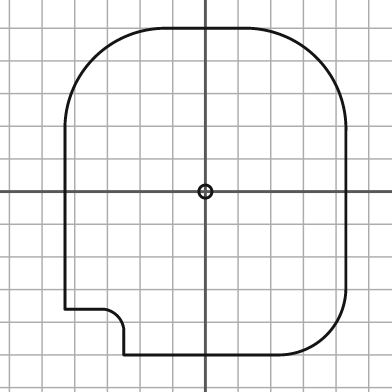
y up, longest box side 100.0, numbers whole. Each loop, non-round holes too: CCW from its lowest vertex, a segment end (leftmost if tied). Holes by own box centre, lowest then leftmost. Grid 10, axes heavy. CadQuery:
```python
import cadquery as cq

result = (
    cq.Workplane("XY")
    .moveTo(-25.0, -50.0)
    .lineTo(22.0, -50.0)
    .threePointArc((37.0, -44.0), (43.0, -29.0))
    .lineTo(43.0, 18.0)
    .threePointArc((34.0, 41.0), (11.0, 50.0))
    .lineTo(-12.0, 50.0)
    .threePointArc((-34.0, 41.0), (-43.0, 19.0))
    .lineTo(-43.0, -36.0)
    .lineTo(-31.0, -36.0)
    .threePointArc((-27.0, -38.0), (-25.0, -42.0))
    .close()
    .moveTo(0.0, 0.0)
    .circle(2.0)
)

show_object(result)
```